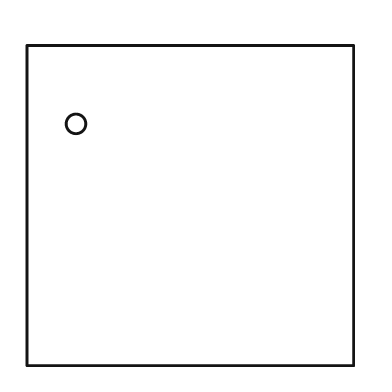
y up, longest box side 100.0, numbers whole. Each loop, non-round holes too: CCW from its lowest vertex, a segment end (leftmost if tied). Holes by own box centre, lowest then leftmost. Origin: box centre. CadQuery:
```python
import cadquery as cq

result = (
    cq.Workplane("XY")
    .moveTo(-50.0, -49.0)
    .lineTo(50.0, -49.0)
    .lineTo(50.0, 49.0)
    .lineTo(-50.0, 49.0)
    .close()
    .moveTo(-35.0, 25.0)
    .circle(3.0)
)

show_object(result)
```